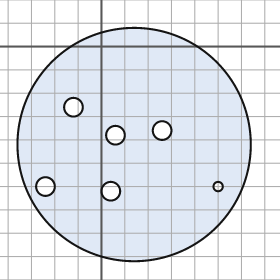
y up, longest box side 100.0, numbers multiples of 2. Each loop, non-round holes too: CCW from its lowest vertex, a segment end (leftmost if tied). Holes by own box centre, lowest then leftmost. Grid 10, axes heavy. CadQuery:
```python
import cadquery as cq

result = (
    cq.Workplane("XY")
    .moveTo(14.0, -42.0)
    .circle(50.0)
    .moveTo(4.0, -62.0)
    .circle(4.0)
    .moveTo(-24.0, -60.0)
    .circle(4.0)
    .moveTo(50.0, -60.0)
    .circle(2.0)
    .moveTo(6.0, -38.0)
    .circle(4.0)
    .moveTo(26.0, -36.0)
    .circle(4.0)
    .moveTo(-12.0, -26.0)
    .circle(4.0)
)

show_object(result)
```